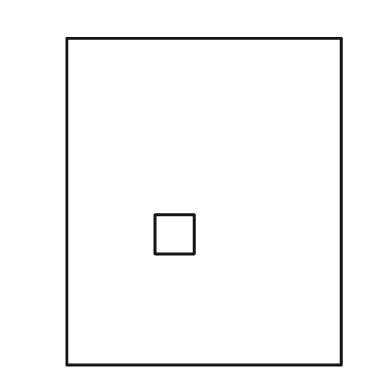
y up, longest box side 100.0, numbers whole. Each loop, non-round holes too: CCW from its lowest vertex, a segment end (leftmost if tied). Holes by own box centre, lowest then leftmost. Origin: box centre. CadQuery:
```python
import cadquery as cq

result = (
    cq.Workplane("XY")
    .moveTo(-42.0, -50.0)
    .lineTo(42.0, -50.0)
    .lineTo(42.0, 50.0)
    .lineTo(-42.0, 50.0)
    .close()
    .moveTo(-15.0, -16.0)
    .lineTo(-3.0, -16.0)
    .lineTo(-3.0, -4.0)
    .lineTo(-15.0, -4.0)
    .close()
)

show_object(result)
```